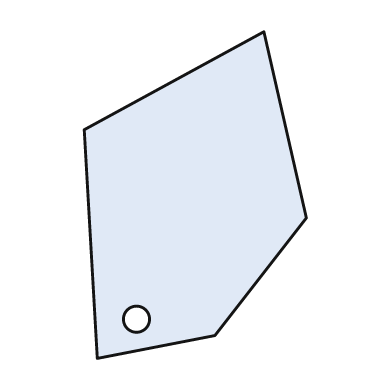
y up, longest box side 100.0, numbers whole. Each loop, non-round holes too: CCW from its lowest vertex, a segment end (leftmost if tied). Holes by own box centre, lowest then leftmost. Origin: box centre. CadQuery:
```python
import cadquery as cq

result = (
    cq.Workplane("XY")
    .moveTo(-30.0, -50.0)
    .lineTo(6.0, -43.0)
    .lineTo(34.0, -7.0)
    .lineTo(21.0, 50.0)
    .lineTo(-34.0, 20.0)
    .close()
    .moveTo(-18.0, -38.0)
    .circle(4.0)
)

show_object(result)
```